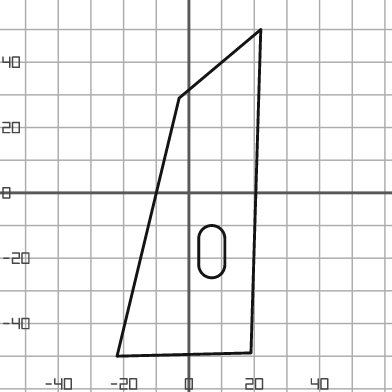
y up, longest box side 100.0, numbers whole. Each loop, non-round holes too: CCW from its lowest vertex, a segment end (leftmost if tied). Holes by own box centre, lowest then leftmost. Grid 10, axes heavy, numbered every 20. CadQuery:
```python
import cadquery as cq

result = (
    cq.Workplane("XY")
    .moveTo(-22.0, -50.0)
    .lineTo(19.0, -49.0)
    .lineTo(22.0, 50.0)
    .lineTo(-3.0, 29.0)
    .close()
    .moveTo(3.0, -22.0)
    .threePointArc((7.0, -26.0), (11.0, -22.0))
    .lineTo(11.0, -14.0)
    .threePointArc((7.0, -10.0), (3.0, -14.0))
    .close()
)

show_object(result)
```